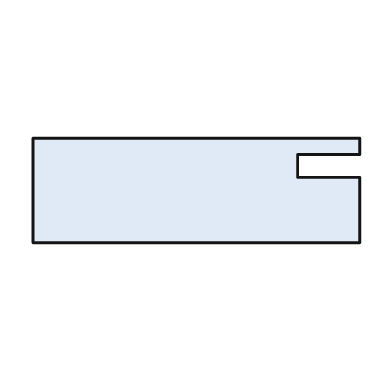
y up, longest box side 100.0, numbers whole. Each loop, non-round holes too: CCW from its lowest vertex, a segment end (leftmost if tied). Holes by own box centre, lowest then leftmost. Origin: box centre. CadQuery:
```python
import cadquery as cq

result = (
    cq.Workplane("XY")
    .moveTo(-50.0, -16.0)
    .lineTo(50.0, -16.0)
    .lineTo(50.0, 4.0)
    .lineTo(31.0, 4.0)
    .lineTo(31.0, 11.0)
    .lineTo(50.0, 11.0)
    .lineTo(50.0, 16.0)
    .lineTo(-50.0, 16.0)
    .close()
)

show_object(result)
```